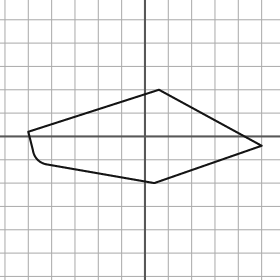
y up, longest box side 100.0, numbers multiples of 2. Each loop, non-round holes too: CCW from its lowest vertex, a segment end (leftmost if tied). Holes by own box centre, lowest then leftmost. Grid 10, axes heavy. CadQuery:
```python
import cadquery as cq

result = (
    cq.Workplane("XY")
    .moveTo(4.0, -20.0)
    .lineTo(50.0, -4.0)
    .lineTo(6.0, 20.0)
    .lineTo(-50.0, 2.0)
    .lineTo(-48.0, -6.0)
    .threePointArc((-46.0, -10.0), (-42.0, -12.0))
    .close()
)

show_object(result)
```